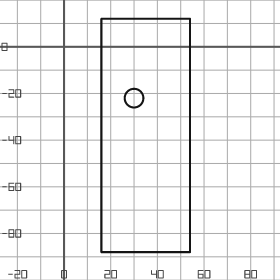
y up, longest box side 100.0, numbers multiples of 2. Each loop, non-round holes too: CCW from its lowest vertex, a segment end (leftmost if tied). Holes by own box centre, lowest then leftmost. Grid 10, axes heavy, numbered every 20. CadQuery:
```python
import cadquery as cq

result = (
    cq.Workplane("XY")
    .moveTo(16.0, -88.0)
    .lineTo(54.0, -88.0)
    .lineTo(54.0, 12.0)
    .lineTo(16.0, 12.0)
    .close()
    .moveTo(30.0, -22.0)
    .circle(4.0)
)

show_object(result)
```